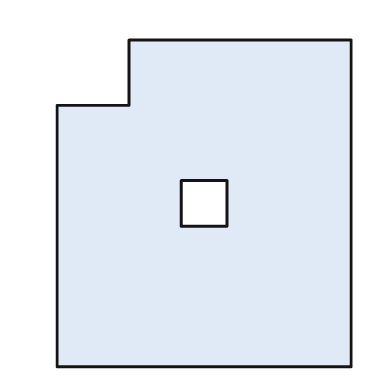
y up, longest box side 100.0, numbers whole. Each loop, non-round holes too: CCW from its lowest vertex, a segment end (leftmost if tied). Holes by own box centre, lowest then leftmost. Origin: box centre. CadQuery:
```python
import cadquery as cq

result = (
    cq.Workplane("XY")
    .moveTo(-45.0, -50.0)
    .lineTo(45.0, -50.0)
    .lineTo(45.0, 50.0)
    .lineTo(-23.0, 50.0)
    .lineTo(-23.0, 30.0)
    .lineTo(-45.0, 30.0)
    .close()
    .moveTo(-7.0, -7.0)
    .lineTo(7.0, -7.0)
    .lineTo(7.0, 7.0)
    .lineTo(-7.0, 7.0)
    .close()
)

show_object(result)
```